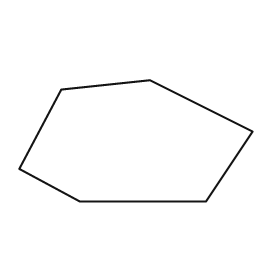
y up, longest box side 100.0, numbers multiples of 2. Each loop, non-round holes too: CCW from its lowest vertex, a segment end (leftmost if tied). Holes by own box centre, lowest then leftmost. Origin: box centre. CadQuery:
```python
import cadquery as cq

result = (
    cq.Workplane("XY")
    .moveTo(-24.0, -26.0)
    .lineTo(30.0, -26.0)
    .lineTo(50.0, 4.0)
    .lineTo(6.0, 26.0)
    .lineTo(-32.0, 22.0)
    .lineTo(-50.0, -12.0)
    .close()
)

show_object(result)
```